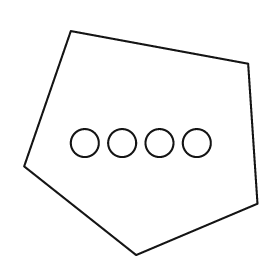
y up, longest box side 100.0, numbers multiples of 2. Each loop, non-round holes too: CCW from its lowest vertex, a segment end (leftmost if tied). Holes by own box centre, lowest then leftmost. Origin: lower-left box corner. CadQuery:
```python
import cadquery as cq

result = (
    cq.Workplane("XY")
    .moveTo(48.0, 0.0)
    .lineTo(100.0, 22.0)
    .lineTo(96.0, 82.0)
    .lineTo(20.0, 96.0)
    .lineTo(0.0, 38.0)
    .close()
    .moveTo(26.0, 48.0)
    .circle(6.0)
    .moveTo(42.0, 48.0)
    .circle(6.0)
    .moveTo(58.0, 48.0)
    .circle(6.0)
    .moveTo(74.0, 48.0)
    .circle(6.0)
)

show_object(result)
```